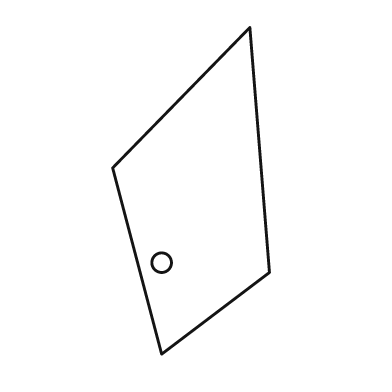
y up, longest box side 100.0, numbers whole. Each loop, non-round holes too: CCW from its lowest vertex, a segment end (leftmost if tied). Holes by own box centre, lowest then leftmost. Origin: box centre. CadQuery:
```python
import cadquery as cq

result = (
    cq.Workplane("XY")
    .moveTo(-9.0, -50.0)
    .lineTo(24.0, -25.0)
    .lineTo(18.0, 50.0)
    .lineTo(-24.0, 7.0)
    .close()
    .moveTo(-9.0, -22.0)
    .circle(3.0)
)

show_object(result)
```